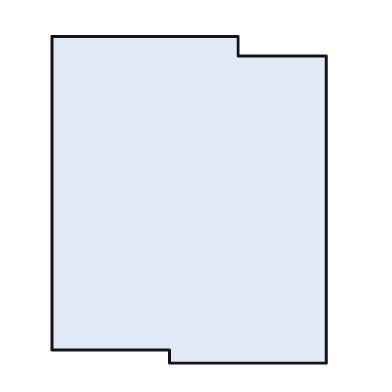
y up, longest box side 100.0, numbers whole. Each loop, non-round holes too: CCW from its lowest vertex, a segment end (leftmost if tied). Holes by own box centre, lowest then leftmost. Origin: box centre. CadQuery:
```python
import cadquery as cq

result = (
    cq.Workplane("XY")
    .moveTo(-6.0, -50.0)
    .lineTo(42.0, -50.0)
    .lineTo(42.0, 44.0)
    .lineTo(15.0, 44.0)
    .lineTo(15.0, 50.0)
    .lineTo(-42.0, 50.0)
    .lineTo(-42.0, -46.0)
    .lineTo(-6.0, -46.0)
    .close()
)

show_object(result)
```